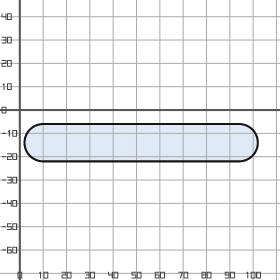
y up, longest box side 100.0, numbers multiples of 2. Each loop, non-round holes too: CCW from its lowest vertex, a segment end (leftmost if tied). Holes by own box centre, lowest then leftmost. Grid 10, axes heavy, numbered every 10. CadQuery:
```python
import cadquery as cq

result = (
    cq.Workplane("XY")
    .moveTo(10.0, -22.0)
    .lineTo(94.0, -22.0)
    .threePointArc((102.0, -14.0), (94.0, -6.0))
    .lineTo(10.0, -6.0)
    .threePointArc((2.0, -14.0), (10.0, -22.0))
    .close()
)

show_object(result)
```